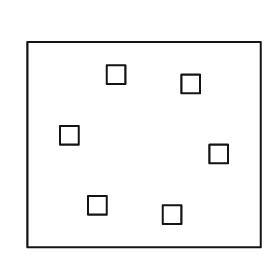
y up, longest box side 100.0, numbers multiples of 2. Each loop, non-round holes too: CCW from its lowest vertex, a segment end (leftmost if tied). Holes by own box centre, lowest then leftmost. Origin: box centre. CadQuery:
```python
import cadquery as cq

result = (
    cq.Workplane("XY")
    .moveTo(-50.0, -44.0)
    .lineTo(50.0, -44.0)
    .lineTo(50.0, 44.0)
    .lineTo(-50.0, 44.0)
    .close()
    .moveTo(8.0, -34.0)
    .lineTo(16.0, -34.0)
    .lineTo(16.0, -26.0)
    .lineTo(8.0, -26.0)
    .close()
    .moveTo(-24.0, -30.0)
    .lineTo(-16.0, -30.0)
    .lineTo(-16.0, -22.0)
    .lineTo(-24.0, -22.0)
    .close()
    .moveTo(28.0, -8.0)
    .lineTo(36.0, -8.0)
    .lineTo(36.0, 0.0)
    .lineTo(28.0, 0.0)
    .close()
    .moveTo(-36.0, 0.0)
    .lineTo(-28.0, 0.0)
    .lineTo(-28.0, 8.0)
    .lineTo(-36.0, 8.0)
    .close()
    .moveTo(16.0, 22.0)
    .lineTo(24.0, 22.0)
    .lineTo(24.0, 30.0)
    .lineTo(16.0, 30.0)
    .close()
    .moveTo(-16.0, 26.0)
    .lineTo(-8.0, 26.0)
    .lineTo(-8.0, 34.0)
    .lineTo(-16.0, 34.0)
    .close()
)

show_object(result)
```